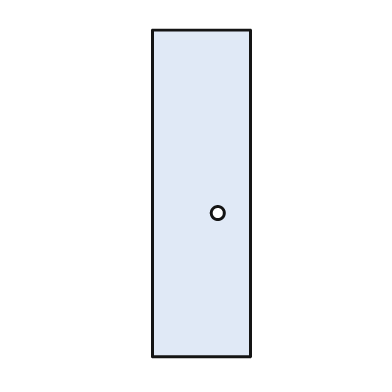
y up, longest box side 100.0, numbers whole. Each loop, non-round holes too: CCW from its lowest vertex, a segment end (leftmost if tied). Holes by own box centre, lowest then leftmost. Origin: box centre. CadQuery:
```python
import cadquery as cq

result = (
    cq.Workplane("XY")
    .moveTo(-15.0, -50.0)
    .lineTo(15.0, -50.0)
    .lineTo(15.0, 50.0)
    .lineTo(-15.0, 50.0)
    .close()
    .moveTo(5.0, -6.0)
    .circle(2.0)
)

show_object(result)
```